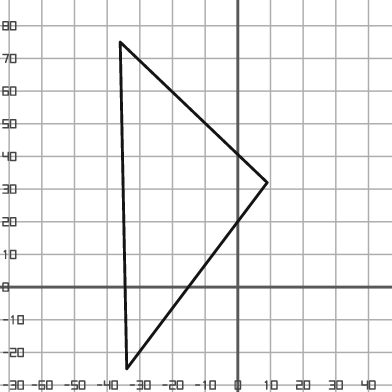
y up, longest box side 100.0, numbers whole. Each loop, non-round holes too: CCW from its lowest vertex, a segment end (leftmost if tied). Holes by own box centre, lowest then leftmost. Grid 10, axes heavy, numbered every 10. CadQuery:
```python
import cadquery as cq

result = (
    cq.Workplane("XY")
    .moveTo(-34.0, -25.0)
    .lineTo(9.0, 32.0)
    .lineTo(-36.0, 75.0)
    .close()
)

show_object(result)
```